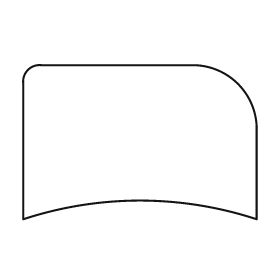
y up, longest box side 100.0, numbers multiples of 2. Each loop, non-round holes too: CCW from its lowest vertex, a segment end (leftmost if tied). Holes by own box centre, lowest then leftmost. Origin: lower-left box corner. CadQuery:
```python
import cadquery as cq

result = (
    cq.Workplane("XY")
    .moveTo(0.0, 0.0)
    .threePointArc((50.0, 8.0), (100.0, 0.0))
    .lineTo(100.0, 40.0)
    .threePointArc((92.0, 58.0), (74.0, 66.0))
    .lineTo(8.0, 66.0)
    .threePointArc((2.0, 64.0), (0.0, 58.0))
    .close()
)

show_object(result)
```